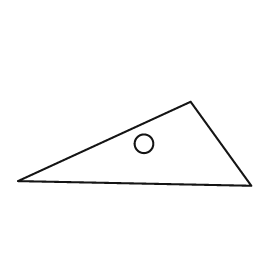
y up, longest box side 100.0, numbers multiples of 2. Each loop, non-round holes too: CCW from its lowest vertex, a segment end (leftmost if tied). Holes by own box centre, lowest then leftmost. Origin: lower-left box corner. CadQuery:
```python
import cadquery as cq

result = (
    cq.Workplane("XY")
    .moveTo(100.0, 0.0)
    .lineTo(74.0, 36.0)
    .lineTo(0.0, 2.0)
    .close()
    .moveTo(54.0, 18.0)
    .circle(4.0)
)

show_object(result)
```